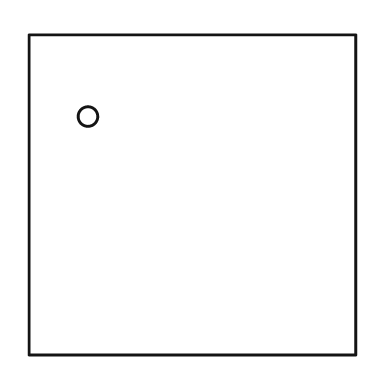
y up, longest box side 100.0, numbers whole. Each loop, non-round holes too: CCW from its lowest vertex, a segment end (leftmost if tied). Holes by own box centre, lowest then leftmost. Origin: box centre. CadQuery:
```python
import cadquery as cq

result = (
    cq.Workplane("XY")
    .moveTo(-50.0, -49.0)
    .lineTo(50.0, -49.0)
    .lineTo(50.0, 49.0)
    .lineTo(-50.0, 49.0)
    .close()
    .moveTo(-32.0, 24.0)
    .circle(3.0)
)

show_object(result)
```